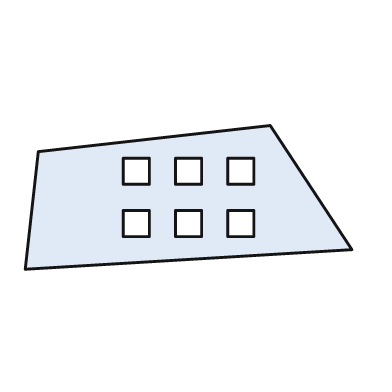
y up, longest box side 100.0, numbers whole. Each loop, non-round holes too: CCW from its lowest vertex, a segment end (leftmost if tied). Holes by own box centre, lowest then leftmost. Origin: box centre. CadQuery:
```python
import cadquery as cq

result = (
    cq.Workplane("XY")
    .moveTo(-50.0, -22.0)
    .lineTo(50.0, -16.0)
    .lineTo(25.0, 22.0)
    .lineTo(-46.0, 14.0)
    .close()
    .moveTo(-20.0, -12.0)
    .lineTo(-12.0, -12.0)
    .lineTo(-12.0, -4.0)
    .lineTo(-20.0, -4.0)
    .close()
    .moveTo(-4.0, -12.0)
    .lineTo(4.0, -12.0)
    .lineTo(4.0, -4.0)
    .lineTo(-4.0, -4.0)
    .close()
    .moveTo(12.0, -12.0)
    .lineTo(20.0, -12.0)
    .lineTo(20.0, -4.0)
    .lineTo(12.0, -4.0)
    .close()
    .moveTo(-20.0, 4.0)
    .lineTo(-12.0, 4.0)
    .lineTo(-12.0, 12.0)
    .lineTo(-20.0, 12.0)
    .close()
    .moveTo(-4.0, 4.0)
    .lineTo(4.0, 4.0)
    .lineTo(4.0, 12.0)
    .lineTo(-4.0, 12.0)
    .close()
    .moveTo(12.0, 4.0)
    .lineTo(20.0, 4.0)
    .lineTo(20.0, 12.0)
    .lineTo(12.0, 12.0)
    .close()
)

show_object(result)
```